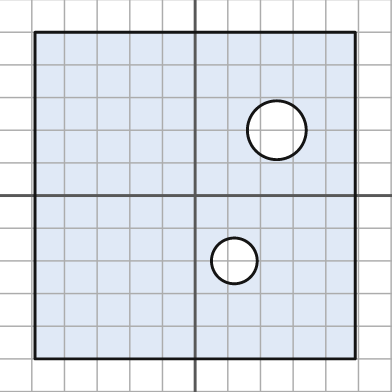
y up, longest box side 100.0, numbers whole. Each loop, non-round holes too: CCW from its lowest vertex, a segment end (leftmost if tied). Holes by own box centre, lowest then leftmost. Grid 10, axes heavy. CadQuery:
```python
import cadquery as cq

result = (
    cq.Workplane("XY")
    .moveTo(-49.0, -50.0)
    .lineTo(49.0, -50.0)
    .lineTo(49.0, 50.0)
    .lineTo(-49.0, 50.0)
    .close()
    .moveTo(12.0, -20.0)
    .circle(7.0)
    .moveTo(25.0, 20.0)
    .circle(9.0)
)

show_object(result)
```